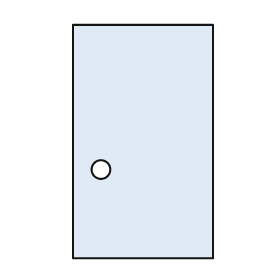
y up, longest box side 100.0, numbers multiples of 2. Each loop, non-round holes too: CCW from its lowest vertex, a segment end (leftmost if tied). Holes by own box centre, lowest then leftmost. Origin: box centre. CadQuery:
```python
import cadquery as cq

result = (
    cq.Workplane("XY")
    .moveTo(-30.0, -50.0)
    .lineTo(30.0, -50.0)
    .lineTo(30.0, 50.0)
    .lineTo(-30.0, 50.0)
    .close()
    .moveTo(-18.0, -12.0)
    .circle(4.0)
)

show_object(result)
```